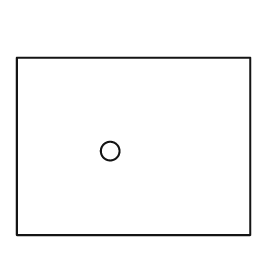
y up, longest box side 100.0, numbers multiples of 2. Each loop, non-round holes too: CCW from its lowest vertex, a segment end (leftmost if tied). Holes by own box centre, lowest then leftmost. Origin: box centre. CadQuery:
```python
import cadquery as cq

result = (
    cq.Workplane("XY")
    .moveTo(-50.0, -38.0)
    .lineTo(50.0, -38.0)
    .lineTo(50.0, 38.0)
    .lineTo(-50.0, 38.0)
    .close()
    .moveTo(-10.0, -2.0)
    .circle(4.0)
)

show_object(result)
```